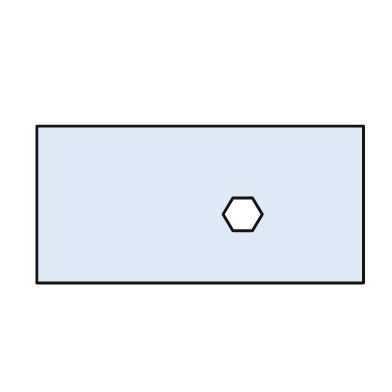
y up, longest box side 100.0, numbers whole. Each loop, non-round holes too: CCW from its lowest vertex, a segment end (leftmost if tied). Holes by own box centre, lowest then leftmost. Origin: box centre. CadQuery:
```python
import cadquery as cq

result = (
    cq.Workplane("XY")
    .moveTo(-50.0, -24.0)
    .lineTo(50.0, -24.0)
    .lineTo(50.0, 24.0)
    .lineTo(-50.0, 24.0)
    .close()
    .moveTo(10.0, -8.0)
    .lineTo(16.0, -8.0)
    .lineTo(19.0, -3.0)
    .lineTo(16.0, 2.0)
    .lineTo(10.0, 2.0)
    .lineTo(7.0, -3.0)
    .close()
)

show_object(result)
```